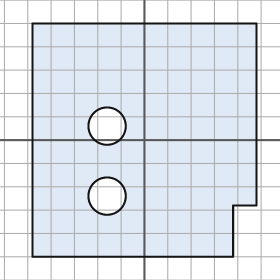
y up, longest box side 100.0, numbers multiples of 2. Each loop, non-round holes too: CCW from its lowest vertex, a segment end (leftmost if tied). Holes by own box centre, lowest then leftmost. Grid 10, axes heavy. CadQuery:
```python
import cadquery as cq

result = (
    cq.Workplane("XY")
    .moveTo(-48.0, -50.0)
    .lineTo(38.0, -50.0)
    .lineTo(38.0, -28.0)
    .lineTo(48.0, -28.0)
    .lineTo(48.0, 50.0)
    .lineTo(-48.0, 50.0)
    .close()
    .moveTo(-16.0, -24.0)
    .circle(8.0)
    .moveTo(-16.0, 6.0)
    .circle(8.0)
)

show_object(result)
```